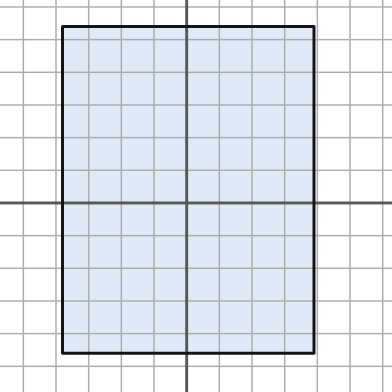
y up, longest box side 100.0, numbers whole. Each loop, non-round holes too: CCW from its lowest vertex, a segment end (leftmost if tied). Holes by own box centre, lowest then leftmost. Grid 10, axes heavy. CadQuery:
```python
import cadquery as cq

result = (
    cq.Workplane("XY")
    .moveTo(-38.0, -46.0)
    .lineTo(39.0, -46.0)
    .lineTo(39.0, 54.0)
    .lineTo(-38.0, 54.0)
    .close()
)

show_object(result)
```